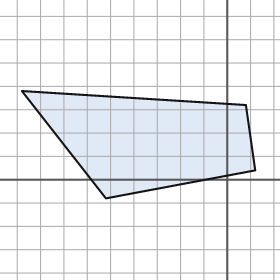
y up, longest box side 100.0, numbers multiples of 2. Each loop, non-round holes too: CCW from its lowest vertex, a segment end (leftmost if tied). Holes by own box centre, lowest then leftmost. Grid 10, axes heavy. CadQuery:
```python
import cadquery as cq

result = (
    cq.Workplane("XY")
    .moveTo(-52.0, -8.0)
    .lineTo(12.0, 4.0)
    .lineTo(8.0, 32.0)
    .lineTo(-88.0, 38.0)
    .close()
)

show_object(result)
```